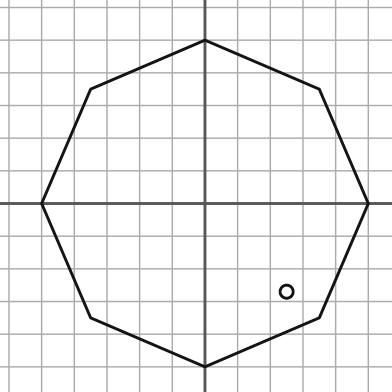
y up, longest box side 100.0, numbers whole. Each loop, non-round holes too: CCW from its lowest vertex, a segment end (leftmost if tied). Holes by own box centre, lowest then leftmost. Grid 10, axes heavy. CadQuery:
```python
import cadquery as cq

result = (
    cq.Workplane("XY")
    .moveTo(0.0, -50.0)
    .lineTo(35.0, -35.0)
    .lineTo(50.0, 0.0)
    .lineTo(35.0, 35.0)
    .lineTo(0.0, 50.0)
    .lineTo(-35.0, 35.0)
    .lineTo(-50.0, 0.0)
    .lineTo(-35.0, -35.0)
    .close()
    .moveTo(25.0, -27.0)
    .circle(2.0)
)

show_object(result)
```